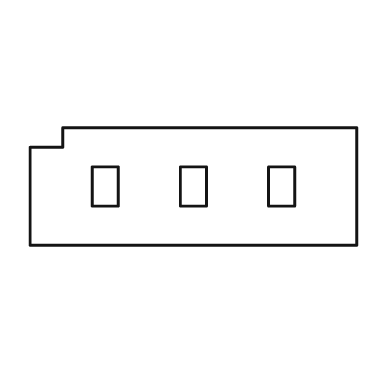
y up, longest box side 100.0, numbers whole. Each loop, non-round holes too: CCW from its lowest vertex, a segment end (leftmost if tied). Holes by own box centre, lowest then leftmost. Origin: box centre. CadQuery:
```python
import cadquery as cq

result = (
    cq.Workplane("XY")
    .moveTo(-50.0, -18.0)
    .lineTo(50.0, -18.0)
    .lineTo(50.0, 18.0)
    .lineTo(-40.0, 18.0)
    .lineTo(-40.0, 12.0)
    .lineTo(-50.0, 12.0)
    .close()
    .moveTo(-31.0, -6.0)
    .lineTo(-23.0, -6.0)
    .lineTo(-23.0, 6.0)
    .lineTo(-31.0, 6.0)
    .close()
    .moveTo(-4.0, -6.0)
    .lineTo(4.0, -6.0)
    .lineTo(4.0, 6.0)
    .lineTo(-4.0, 6.0)
    .close()
    .moveTo(23.0, -6.0)
    .lineTo(31.0, -6.0)
    .lineTo(31.0, 6.0)
    .lineTo(23.0, 6.0)
    .close()
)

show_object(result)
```